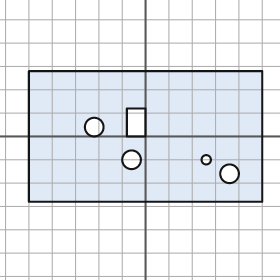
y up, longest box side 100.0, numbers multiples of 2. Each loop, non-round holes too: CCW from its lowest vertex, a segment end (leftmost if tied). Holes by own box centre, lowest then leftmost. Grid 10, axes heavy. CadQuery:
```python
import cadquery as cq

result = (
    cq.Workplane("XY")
    .moveTo(-50.0, -28.0)
    .lineTo(50.0, -28.0)
    .lineTo(50.0, 28.0)
    .lineTo(-50.0, 28.0)
    .close()
    .moveTo(36.0, -16.0)
    .circle(4.0)
    .moveTo(-6.0, -10.0)
    .circle(4.0)
    .moveTo(26.0, -10.0)
    .circle(2.0)
    .moveTo(-22.0, 4.0)
    .circle(4.0)
    .moveTo(-8.0, 0.0)
    .lineTo(0.0, 0.0)
    .lineTo(0.0, 12.0)
    .lineTo(-8.0, 12.0)
    .close()
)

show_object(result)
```